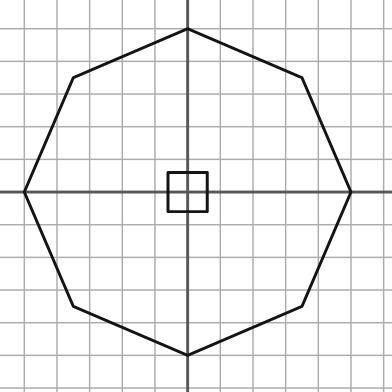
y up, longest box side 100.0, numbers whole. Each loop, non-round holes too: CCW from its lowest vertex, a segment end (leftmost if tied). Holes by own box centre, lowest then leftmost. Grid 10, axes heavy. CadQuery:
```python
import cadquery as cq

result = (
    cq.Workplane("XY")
    .moveTo(0.0, -50.0)
    .lineTo(35.0, -35.0)
    .lineTo(50.0, 0.0)
    .lineTo(35.0, 35.0)
    .lineTo(0.0, 50.0)
    .lineTo(-35.0, 35.0)
    .lineTo(-50.0, 0.0)
    .lineTo(-35.0, -35.0)
    .close()
    .moveTo(-6.0, -6.0)
    .lineTo(6.0, -6.0)
    .lineTo(6.0, 6.0)
    .lineTo(-6.0, 6.0)
    .close()
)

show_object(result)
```